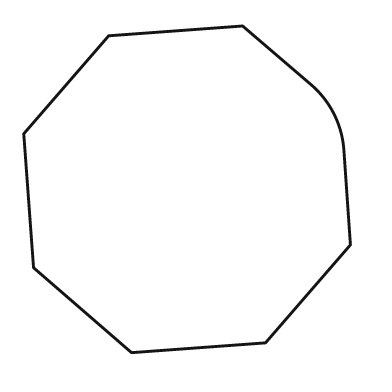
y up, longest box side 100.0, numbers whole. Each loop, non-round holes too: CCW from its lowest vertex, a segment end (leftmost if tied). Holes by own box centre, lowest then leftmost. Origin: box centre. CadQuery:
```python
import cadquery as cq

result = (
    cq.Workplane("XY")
    .moveTo(-17.0, -50.0)
    .lineTo(24.0, -47.0)
    .lineTo(50.0, -17.0)
    .lineTo(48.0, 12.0)
    .threePointArc((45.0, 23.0), (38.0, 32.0))
    .lineTo(17.0, 50.0)
    .lineTo(-24.0, 47.0)
    .lineTo(-50.0, 17.0)
    .lineTo(-47.0, -24.0)
    .close()
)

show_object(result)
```